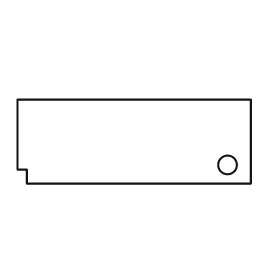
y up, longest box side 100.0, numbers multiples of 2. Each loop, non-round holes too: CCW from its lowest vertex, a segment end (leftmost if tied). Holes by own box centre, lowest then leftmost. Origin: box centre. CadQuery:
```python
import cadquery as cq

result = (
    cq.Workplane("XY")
    .moveTo(-46.0, -18.0)
    .lineTo(50.0, -18.0)
    .lineTo(50.0, 18.0)
    .lineTo(-50.0, 18.0)
    .lineTo(-50.0, -12.0)
    .lineTo(-46.0, -12.0)
    .close()
    .moveTo(40.0, -10.0)
    .circle(4.0)
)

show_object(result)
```